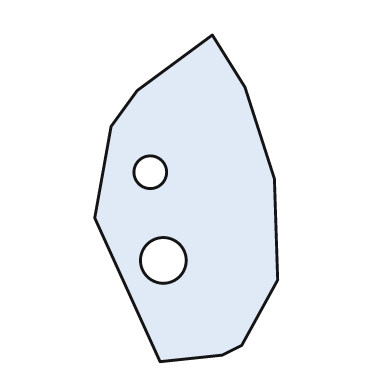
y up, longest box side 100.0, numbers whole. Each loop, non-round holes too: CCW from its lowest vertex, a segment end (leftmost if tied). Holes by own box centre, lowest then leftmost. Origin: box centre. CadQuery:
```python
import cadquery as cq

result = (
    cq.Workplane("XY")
    .moveTo(-8.0, -50.0)
    .lineTo(11.0, -48.0)
    .lineTo(17.0, -45.0)
    .lineTo(28.0, -25.0)
    .lineTo(27.0, 6.0)
    .lineTo(18.0, 34.0)
    .lineTo(8.0, 50.0)
    .lineTo(-15.0, 33.0)
    .lineTo(-23.0, 22.0)
    .lineTo(-28.0, -6.0)
    .close()
    .moveTo(-7.0, -19.0)
    .circle(7.0)
    .moveTo(-11.0, 8.0)
    .circle(5.0)
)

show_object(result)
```